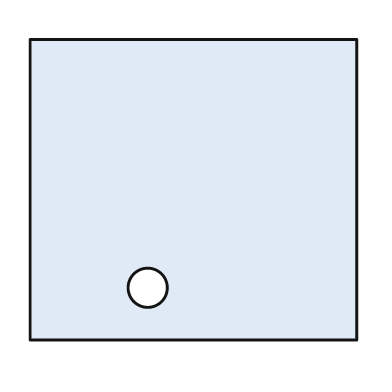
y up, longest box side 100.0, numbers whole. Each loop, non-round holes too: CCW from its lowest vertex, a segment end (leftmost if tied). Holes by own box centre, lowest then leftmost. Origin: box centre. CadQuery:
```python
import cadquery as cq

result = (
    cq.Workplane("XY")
    .moveTo(-50.0, -46.0)
    .lineTo(50.0, -46.0)
    .lineTo(50.0, 46.0)
    .lineTo(-50.0, 46.0)
    .close()
    .moveTo(-14.0, -30.0)
    .circle(6.0)
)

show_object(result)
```